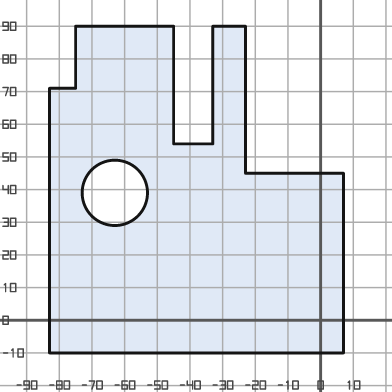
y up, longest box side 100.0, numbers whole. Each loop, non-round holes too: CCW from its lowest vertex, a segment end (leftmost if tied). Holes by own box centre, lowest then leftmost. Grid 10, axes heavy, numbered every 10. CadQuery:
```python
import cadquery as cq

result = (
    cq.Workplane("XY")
    .moveTo(-83.0, -10.0)
    .lineTo(7.0, -10.0)
    .lineTo(7.0, 45.0)
    .lineTo(-23.0, 45.0)
    .lineTo(-23.0, 90.0)
    .lineTo(-33.0, 90.0)
    .lineTo(-33.0, 54.0)
    .lineTo(-45.0, 54.0)
    .lineTo(-45.0, 90.0)
    .lineTo(-75.0, 90.0)
    .lineTo(-75.0, 71.0)
    .lineTo(-83.0, 71.0)
    .close()
    .moveTo(-63.0, 39.0)
    .circle(10.0)
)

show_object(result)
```